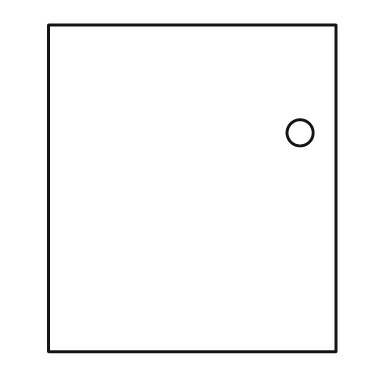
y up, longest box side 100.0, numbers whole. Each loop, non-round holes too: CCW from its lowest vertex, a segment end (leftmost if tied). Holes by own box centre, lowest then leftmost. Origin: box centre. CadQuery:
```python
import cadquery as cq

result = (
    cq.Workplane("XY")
    .moveTo(-44.0, -50.0)
    .lineTo(44.0, -50.0)
    .lineTo(44.0, 50.0)
    .lineTo(-44.0, 50.0)
    .close()
    .moveTo(33.0, 17.0)
    .circle(4.0)
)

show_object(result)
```